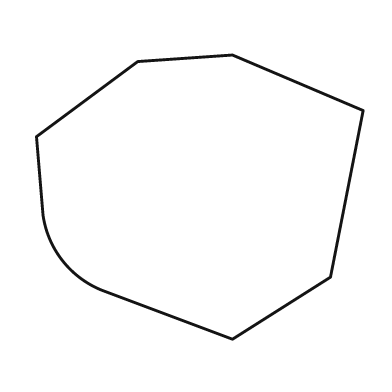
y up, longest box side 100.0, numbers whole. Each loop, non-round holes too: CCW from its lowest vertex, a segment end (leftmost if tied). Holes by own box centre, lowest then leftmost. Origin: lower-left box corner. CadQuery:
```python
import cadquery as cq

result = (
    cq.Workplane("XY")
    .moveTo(60.0, 0.0)
    .lineTo(90.0, 19.0)
    .lineTo(100.0, 70.0)
    .lineTo(60.0, 87.0)
    .lineTo(31.0, 85.0)
    .lineTo(0.0, 62.0)
    .lineTo(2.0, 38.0)
    .threePointArc((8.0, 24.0), (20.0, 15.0))
    .close()
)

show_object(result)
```